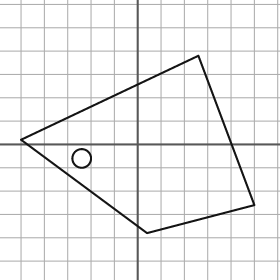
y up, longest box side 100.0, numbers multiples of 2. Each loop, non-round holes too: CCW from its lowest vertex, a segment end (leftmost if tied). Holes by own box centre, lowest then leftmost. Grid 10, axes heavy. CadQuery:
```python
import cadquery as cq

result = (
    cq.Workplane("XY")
    .moveTo(4.0, -38.0)
    .lineTo(50.0, -26.0)
    .lineTo(26.0, 38.0)
    .lineTo(-50.0, 2.0)
    .close()
    .moveTo(-24.0, -6.0)
    .circle(4.0)
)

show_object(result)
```